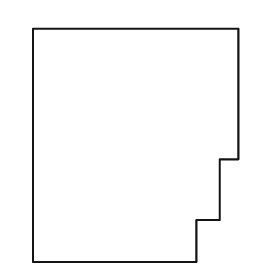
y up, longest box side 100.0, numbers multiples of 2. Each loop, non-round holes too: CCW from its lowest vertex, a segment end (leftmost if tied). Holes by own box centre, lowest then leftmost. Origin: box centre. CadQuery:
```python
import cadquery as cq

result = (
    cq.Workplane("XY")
    .moveTo(-44.0, -50.0)
    .lineTo(26.0, -50.0)
    .lineTo(26.0, -32.0)
    .lineTo(36.0, -32.0)
    .lineTo(36.0, -6.0)
    .lineTo(44.0, -6.0)
    .lineTo(44.0, 50.0)
    .lineTo(-44.0, 50.0)
    .close()
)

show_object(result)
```